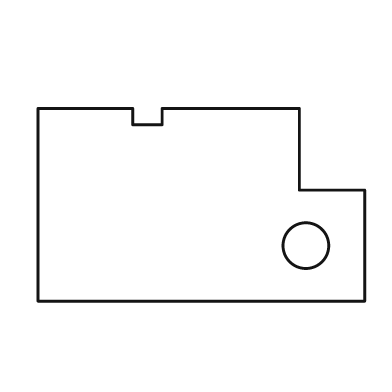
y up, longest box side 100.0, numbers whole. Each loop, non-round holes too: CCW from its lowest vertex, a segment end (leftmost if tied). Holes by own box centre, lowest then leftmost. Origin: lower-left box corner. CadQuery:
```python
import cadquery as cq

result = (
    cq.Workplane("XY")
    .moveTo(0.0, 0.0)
    .lineTo(100.0, 0.0)
    .lineTo(100.0, 34.0)
    .lineTo(80.0, 34.0)
    .lineTo(80.0, 59.0)
    .lineTo(38.0, 59.0)
    .lineTo(38.0, 54.0)
    .lineTo(29.0, 54.0)
    .lineTo(29.0, 59.0)
    .lineTo(0.0, 59.0)
    .close()
    .moveTo(82.0, 17.0)
    .circle(7.0)
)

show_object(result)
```